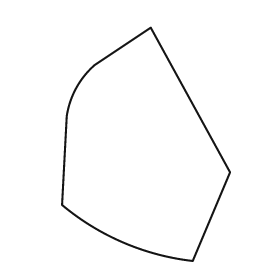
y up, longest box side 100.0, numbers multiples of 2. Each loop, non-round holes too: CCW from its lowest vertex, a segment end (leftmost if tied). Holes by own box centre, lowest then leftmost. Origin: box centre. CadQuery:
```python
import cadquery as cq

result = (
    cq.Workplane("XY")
    .moveTo(20.0, -50.0)
    .lineTo(36.0, -12.0)
    .lineTo(2.0, 50.0)
    .lineTo(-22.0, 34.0)
    .threePointArc((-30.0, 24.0), (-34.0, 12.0))
    .lineTo(-36.0, -26.0)
    .threePointArc((-10.0, -42.0), (20.0, -50.0))
    .close()
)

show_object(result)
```